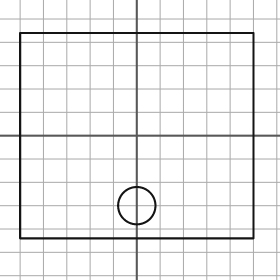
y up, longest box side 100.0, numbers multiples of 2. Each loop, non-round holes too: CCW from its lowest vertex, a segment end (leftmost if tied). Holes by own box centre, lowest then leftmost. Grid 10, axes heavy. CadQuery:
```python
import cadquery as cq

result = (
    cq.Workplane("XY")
    .moveTo(-50.0, -44.0)
    .lineTo(50.0, -44.0)
    .lineTo(50.0, 44.0)
    .lineTo(-50.0, 44.0)
    .close()
    .moveTo(0.0, -30.0)
    .circle(8.0)
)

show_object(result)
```